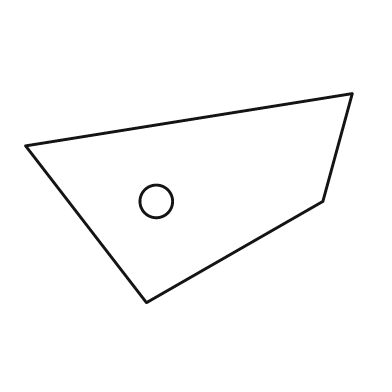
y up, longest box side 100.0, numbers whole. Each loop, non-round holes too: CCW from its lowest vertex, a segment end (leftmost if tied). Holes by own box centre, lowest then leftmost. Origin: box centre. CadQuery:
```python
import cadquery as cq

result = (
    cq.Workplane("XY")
    .moveTo(-13.0, -32.0)
    .lineTo(41.0, -1.0)
    .lineTo(50.0, 32.0)
    .lineTo(-50.0, 16.0)
    .close()
    .moveTo(-10.0, -1.0)
    .circle(5.0)
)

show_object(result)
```